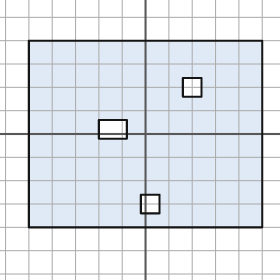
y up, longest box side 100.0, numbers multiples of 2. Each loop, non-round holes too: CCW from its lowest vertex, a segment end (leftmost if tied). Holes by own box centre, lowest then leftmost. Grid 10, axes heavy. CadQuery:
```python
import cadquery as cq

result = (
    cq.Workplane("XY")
    .moveTo(-50.0, -40.0)
    .lineTo(50.0, -40.0)
    .lineTo(50.0, 40.0)
    .lineTo(-50.0, 40.0)
    .close()
    .moveTo(-2.0, -34.0)
    .lineTo(6.0, -34.0)
    .lineTo(6.0, -26.0)
    .lineTo(-2.0, -26.0)
    .close()
    .moveTo(-20.0, -2.0)
    .lineTo(-8.0, -2.0)
    .lineTo(-8.0, 6.0)
    .lineTo(-20.0, 6.0)
    .close()
    .moveTo(16.0, 16.0)
    .lineTo(24.0, 16.0)
    .lineTo(24.0, 24.0)
    .lineTo(16.0, 24.0)
    .close()
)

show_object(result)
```